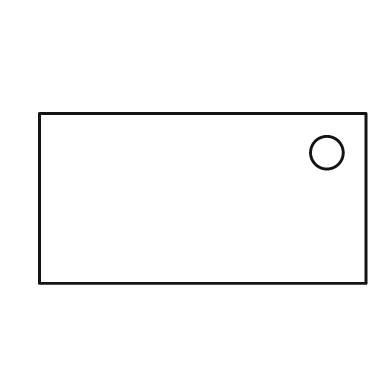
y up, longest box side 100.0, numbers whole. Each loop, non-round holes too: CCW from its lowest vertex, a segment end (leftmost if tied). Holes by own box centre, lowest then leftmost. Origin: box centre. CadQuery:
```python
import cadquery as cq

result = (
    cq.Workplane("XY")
    .moveTo(-50.0, -26.0)
    .lineTo(50.0, -26.0)
    .lineTo(50.0, 26.0)
    .lineTo(-50.0, 26.0)
    .close()
    .moveTo(38.0, 14.0)
    .circle(5.0)
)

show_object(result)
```